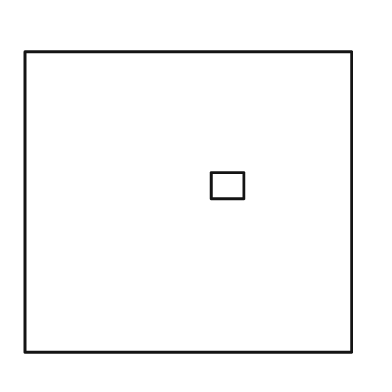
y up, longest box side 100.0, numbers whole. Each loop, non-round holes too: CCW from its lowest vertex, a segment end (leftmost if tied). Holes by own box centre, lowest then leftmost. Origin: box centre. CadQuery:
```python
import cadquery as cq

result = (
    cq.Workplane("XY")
    .moveTo(-50.0, -46.0)
    .lineTo(50.0, -46.0)
    .lineTo(50.0, 46.0)
    .lineTo(-50.0, 46.0)
    .close()
    .moveTo(7.0, 1.0)
    .lineTo(17.0, 1.0)
    .lineTo(17.0, 9.0)
    .lineTo(7.0, 9.0)
    .close()
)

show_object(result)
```